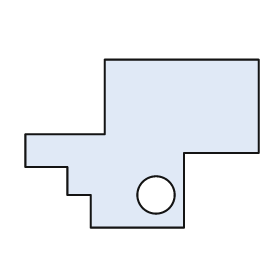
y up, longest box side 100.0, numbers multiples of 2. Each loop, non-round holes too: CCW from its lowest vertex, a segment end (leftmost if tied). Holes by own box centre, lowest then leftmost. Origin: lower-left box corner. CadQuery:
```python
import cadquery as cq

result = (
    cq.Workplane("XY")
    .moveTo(28.0, 0.0)
    .lineTo(68.0, 0.0)
    .lineTo(68.0, 32.0)
    .lineTo(100.0, 32.0)
    .lineTo(100.0, 72.0)
    .lineTo(34.0, 72.0)
    .lineTo(34.0, 40.0)
    .lineTo(0.0, 40.0)
    .lineTo(0.0, 26.0)
    .lineTo(18.0, 26.0)
    .lineTo(18.0, 14.0)
    .lineTo(28.0, 14.0)
    .close()
    .moveTo(56.0, 14.0)
    .circle(8.0)
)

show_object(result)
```